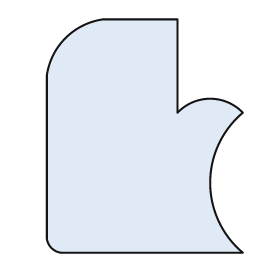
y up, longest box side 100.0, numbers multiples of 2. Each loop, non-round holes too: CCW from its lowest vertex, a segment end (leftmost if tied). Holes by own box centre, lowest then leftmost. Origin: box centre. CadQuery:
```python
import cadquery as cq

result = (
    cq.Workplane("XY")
    .moveTo(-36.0, -50.0)
    .lineTo(42.0, -50.0)
    .threePointArc((28.0, -20.0), (42.0, 10.0))
    .threePointArc((28.0, 16.0), (14.0, 10.0))
    .lineTo(14.0, 50.0)
    .lineTo(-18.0, 50.0)
    .threePointArc((-34.0, 42.0), (-42.0, 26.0))
    .lineTo(-42.0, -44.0)
    .threePointArc((-40.0, -48.0), (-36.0, -50.0))
    .close()
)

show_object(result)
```